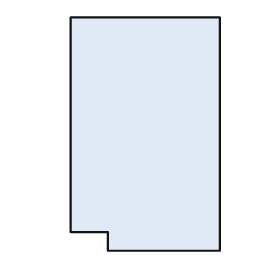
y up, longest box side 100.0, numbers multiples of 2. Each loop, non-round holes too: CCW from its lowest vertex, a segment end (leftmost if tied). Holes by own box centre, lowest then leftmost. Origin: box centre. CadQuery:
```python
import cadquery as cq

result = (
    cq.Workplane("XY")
    .moveTo(-16.0, -50.0)
    .lineTo(32.0, -50.0)
    .lineTo(32.0, 50.0)
    .lineTo(-32.0, 50.0)
    .lineTo(-32.0, -42.0)
    .lineTo(-16.0, -42.0)
    .close()
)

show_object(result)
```